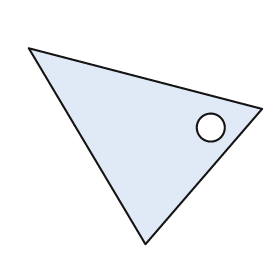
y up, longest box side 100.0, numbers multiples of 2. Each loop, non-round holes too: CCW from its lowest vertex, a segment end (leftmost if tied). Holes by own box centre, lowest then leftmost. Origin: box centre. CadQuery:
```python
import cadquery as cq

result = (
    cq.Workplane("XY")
    .moveTo(0.0, -42.0)
    .lineTo(50.0, 16.0)
    .lineTo(-50.0, 42.0)
    .close()
    .moveTo(28.0, 8.0)
    .circle(6.0)
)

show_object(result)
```